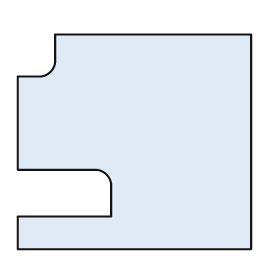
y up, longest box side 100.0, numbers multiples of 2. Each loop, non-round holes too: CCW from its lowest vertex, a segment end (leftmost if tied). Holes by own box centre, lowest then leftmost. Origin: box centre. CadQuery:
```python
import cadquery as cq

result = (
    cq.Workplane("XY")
    .moveTo(-50.0, -46.0)
    .lineTo(50.0, -46.0)
    .lineTo(50.0, 46.0)
    .lineTo(-34.0, 46.0)
    .lineTo(-34.0, 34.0)
    .threePointArc((-36.0, 30.0), (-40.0, 28.0))
    .lineTo(-50.0, 28.0)
    .lineTo(-50.0, -12.0)
    .lineTo(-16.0, -12.0)
    .threePointArc((-12.0, -14.0), (-10.0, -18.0))
    .lineTo(-10.0, -32.0)
    .lineTo(-50.0, -32.0)
    .close()
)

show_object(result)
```